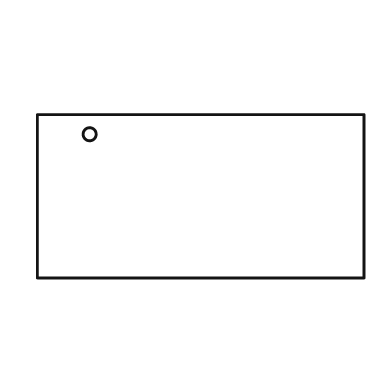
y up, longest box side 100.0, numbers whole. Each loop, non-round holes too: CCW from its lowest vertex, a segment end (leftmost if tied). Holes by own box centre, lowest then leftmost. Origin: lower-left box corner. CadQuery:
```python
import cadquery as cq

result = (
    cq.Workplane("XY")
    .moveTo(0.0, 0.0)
    .lineTo(100.0, 0.0)
    .lineTo(100.0, 50.0)
    .lineTo(0.0, 50.0)
    .close()
    .moveTo(16.0, 44.0)
    .circle(2.0)
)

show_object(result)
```